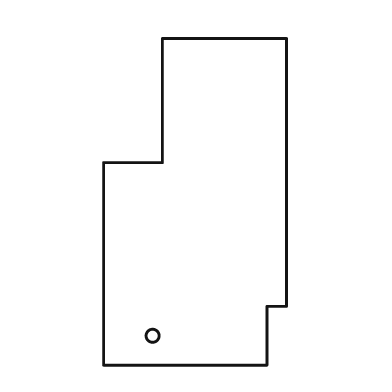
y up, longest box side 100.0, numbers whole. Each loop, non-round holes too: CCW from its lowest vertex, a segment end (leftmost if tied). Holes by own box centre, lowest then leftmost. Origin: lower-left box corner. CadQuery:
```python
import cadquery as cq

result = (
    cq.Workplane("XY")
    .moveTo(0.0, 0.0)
    .lineTo(50.0, 0.0)
    .lineTo(50.0, 18.0)
    .lineTo(56.0, 18.0)
    .lineTo(56.0, 100.0)
    .lineTo(18.0, 100.0)
    .lineTo(18.0, 62.0)
    .lineTo(0.0, 62.0)
    .close()
    .moveTo(15.0, 9.0)
    .circle(2.0)
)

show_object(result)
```